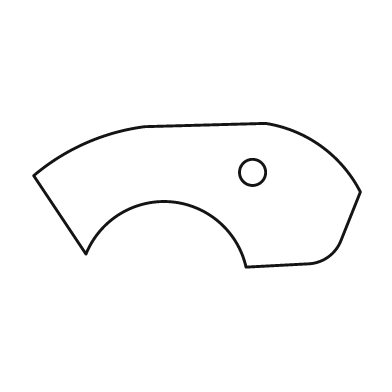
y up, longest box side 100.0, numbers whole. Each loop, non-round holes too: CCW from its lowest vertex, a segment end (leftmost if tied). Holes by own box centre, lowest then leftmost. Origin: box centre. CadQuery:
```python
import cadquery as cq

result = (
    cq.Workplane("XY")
    .moveTo(15.0, -22.0)
    .lineTo(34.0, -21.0)
    .threePointArc((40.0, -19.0), (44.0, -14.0))
    .lineTo(50.0, 1.0)
    .threePointArc((38.0, 15.0), (21.0, 22.0))
    .lineTo(-16.0, 21.0)
    .threePointArc((-34.0, 16.0), (-50.0, 6.0))
    .lineTo(-34.0, -18.0)
    .threePointArc((-8.0, -2.0), (15.0, -22.0))
    .close()
    .moveTo(17.0, 7.0)
    .circle(4.0)
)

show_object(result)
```